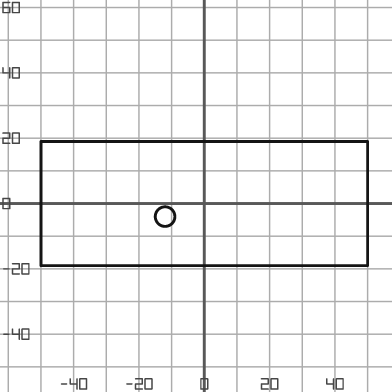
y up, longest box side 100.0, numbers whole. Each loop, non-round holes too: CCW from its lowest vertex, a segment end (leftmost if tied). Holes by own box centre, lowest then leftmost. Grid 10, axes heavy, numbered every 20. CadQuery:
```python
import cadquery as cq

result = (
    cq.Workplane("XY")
    .moveTo(-50.0, -19.0)
    .lineTo(50.0, -19.0)
    .lineTo(50.0, 19.0)
    .lineTo(-50.0, 19.0)
    .close()
    .moveTo(-12.0, -4.0)
    .circle(3.0)
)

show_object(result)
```